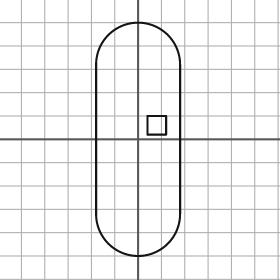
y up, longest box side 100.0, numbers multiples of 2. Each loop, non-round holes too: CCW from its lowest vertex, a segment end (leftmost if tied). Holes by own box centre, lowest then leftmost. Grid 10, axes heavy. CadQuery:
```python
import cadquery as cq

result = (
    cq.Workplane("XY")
    .moveTo(-18.0, -32.0)
    .threePointArc((0.0, -50.0), (18.0, -32.0))
    .lineTo(18.0, 32.0)
    .threePointArc((0.0, 50.0), (-18.0, 32.0))
    .close()
    .moveTo(4.0, 2.0)
    .lineTo(12.0, 2.0)
    .lineTo(12.0, 10.0)
    .lineTo(4.0, 10.0)
    .close()
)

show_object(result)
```